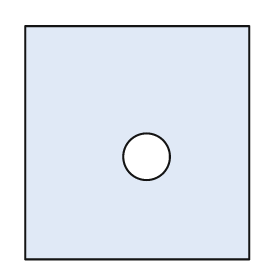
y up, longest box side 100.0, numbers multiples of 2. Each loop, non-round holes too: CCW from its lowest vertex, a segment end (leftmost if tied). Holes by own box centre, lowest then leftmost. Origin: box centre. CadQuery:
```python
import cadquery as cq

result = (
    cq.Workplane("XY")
    .moveTo(-48.0, -50.0)
    .lineTo(48.0, -50.0)
    .lineTo(48.0, 50.0)
    .lineTo(-48.0, 50.0)
    .close()
    .moveTo(4.0, -6.0)
    .circle(10.0)
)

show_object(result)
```